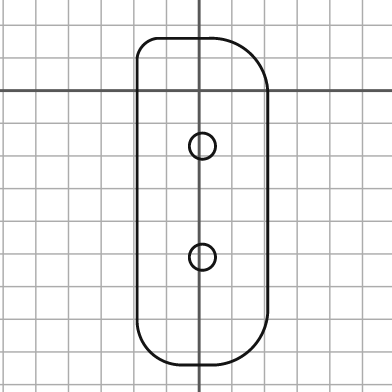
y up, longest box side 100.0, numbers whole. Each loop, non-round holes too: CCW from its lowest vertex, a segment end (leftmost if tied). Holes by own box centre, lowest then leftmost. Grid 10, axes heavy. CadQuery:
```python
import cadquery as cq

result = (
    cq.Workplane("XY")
    .moveTo(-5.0, -84.0)
    .lineTo(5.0, -84.0)
    .threePointArc((16.0, -79.0), (21.0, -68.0))
    .lineTo(21.0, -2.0)
    .threePointArc((16.0, 11.0), (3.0, 16.0))
    .lineTo(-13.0, 16.0)
    .threePointArc((-17.0, 14.0), (-19.0, 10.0))
    .lineTo(-19.0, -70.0)
    .threePointArc((-15.0, -80.0), (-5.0, -84.0))
    .close()
    .moveTo(1.0, -51.0)
    .circle(4.0)
    .moveTo(1.0, -17.0)
    .circle(4.0)
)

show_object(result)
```